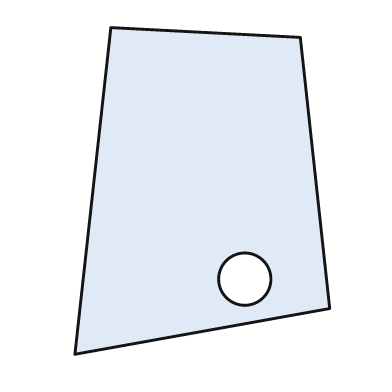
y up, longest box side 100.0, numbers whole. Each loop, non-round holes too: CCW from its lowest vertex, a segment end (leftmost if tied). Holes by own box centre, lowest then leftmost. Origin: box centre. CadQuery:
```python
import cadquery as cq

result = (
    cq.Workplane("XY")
    .moveTo(-39.0, -50.0)
    .lineTo(39.0, -36.0)
    .lineTo(30.0, 47.0)
    .lineTo(-28.0, 50.0)
    .close()
    .moveTo(13.0, -27.0)
    .circle(8.0)
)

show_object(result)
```